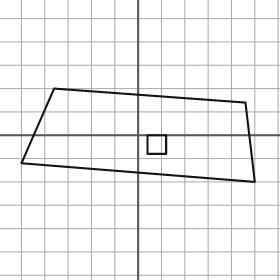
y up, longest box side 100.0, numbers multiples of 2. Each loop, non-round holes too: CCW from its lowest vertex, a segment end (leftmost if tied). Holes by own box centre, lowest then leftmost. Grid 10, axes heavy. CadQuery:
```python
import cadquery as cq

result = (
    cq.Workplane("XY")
    .moveTo(50.0, -20.0)
    .lineTo(46.0, 14.0)
    .lineTo(-36.0, 20.0)
    .lineTo(-50.0, -12.0)
    .close()
    .moveTo(4.0, -8.0)
    .lineTo(12.0, -8.0)
    .lineTo(12.0, 0.0)
    .lineTo(4.0, 0.0)
    .close()
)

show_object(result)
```